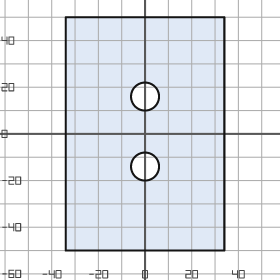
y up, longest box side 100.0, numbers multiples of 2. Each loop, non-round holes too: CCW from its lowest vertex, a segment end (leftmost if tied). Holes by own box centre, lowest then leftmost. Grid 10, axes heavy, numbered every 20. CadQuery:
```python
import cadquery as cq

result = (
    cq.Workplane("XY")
    .moveTo(-34.0, -50.0)
    .lineTo(34.0, -50.0)
    .lineTo(34.0, 50.0)
    .lineTo(-34.0, 50.0)
    .close()
    .moveTo(0.0, -14.0)
    .circle(6.0)
    .moveTo(0.0, 16.0)
    .circle(6.0)
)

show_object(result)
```